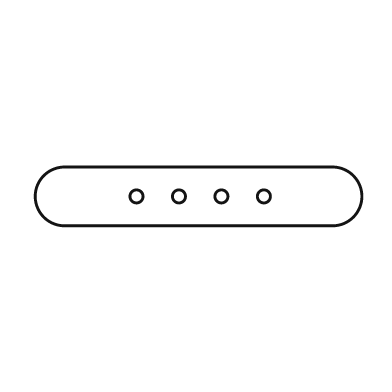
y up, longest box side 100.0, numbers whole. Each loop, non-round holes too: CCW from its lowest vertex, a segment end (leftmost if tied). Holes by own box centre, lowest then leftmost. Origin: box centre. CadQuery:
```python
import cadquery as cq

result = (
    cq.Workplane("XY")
    .moveTo(-41.0, -9.0)
    .lineTo(41.0, -9.0)
    .threePointArc((50.0, 0.0), (41.0, 9.0))
    .lineTo(-41.0, 9.0)
    .threePointArc((-50.0, 0.0), (-41.0, -9.0))
    .close()
    .moveTo(-19.0, 0.0)
    .circle(2.0)
    .moveTo(-6.0, 0.0)
    .circle(2.0)
    .moveTo(7.0, 0.0)
    .circle(2.0)
    .moveTo(20.0, 0.0)
    .circle(2.0)
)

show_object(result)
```